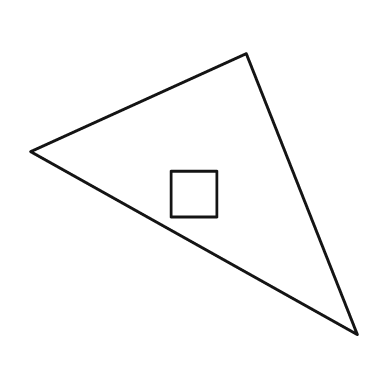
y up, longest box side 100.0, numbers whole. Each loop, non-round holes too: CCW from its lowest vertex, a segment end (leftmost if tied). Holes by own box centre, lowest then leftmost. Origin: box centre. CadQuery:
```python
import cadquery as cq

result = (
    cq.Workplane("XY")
    .moveTo(50.0, -43.0)
    .lineTo(16.0, 43.0)
    .lineTo(-50.0, 13.0)
    .close()
    .moveTo(-7.0, -7.0)
    .lineTo(7.0, -7.0)
    .lineTo(7.0, 7.0)
    .lineTo(-7.0, 7.0)
    .close()
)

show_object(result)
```